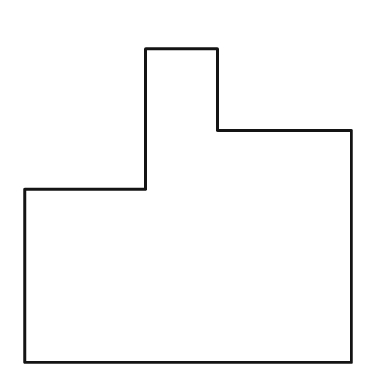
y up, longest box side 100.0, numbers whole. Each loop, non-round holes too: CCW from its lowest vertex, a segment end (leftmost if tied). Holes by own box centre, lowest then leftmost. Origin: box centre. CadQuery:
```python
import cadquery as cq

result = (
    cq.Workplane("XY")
    .moveTo(-50.0, -48.0)
    .lineTo(50.0, -48.0)
    .lineTo(50.0, 23.0)
    .lineTo(9.0, 23.0)
    .lineTo(9.0, 48.0)
    .lineTo(-13.0, 48.0)
    .lineTo(-13.0, 5.0)
    .lineTo(-50.0, 5.0)
    .close()
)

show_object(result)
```